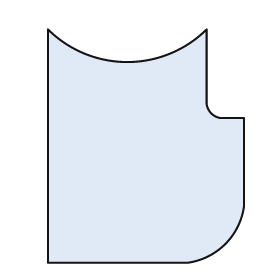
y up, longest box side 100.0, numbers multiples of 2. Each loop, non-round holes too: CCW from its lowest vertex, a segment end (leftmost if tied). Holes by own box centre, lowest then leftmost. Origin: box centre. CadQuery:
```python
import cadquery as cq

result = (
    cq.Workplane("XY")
    .moveTo(-42.0, -50.0)
    .lineTo(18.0, -50.0)
    .threePointArc((34.0, -42.0), (42.0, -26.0))
    .lineTo(42.0, 12.0)
    .lineTo(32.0, 12.0)
    .threePointArc((28.0, 14.0), (26.0, 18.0))
    .lineTo(26.0, 50.0)
    .threePointArc((-8.0, 36.0), (-42.0, 50.0))
    .close()
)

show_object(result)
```